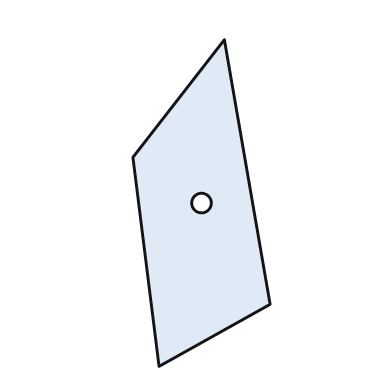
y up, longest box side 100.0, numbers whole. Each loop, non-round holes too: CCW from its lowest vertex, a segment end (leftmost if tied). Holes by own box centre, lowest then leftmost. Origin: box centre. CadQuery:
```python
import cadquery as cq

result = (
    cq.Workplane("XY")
    .moveTo(-13.0, -50.0)
    .lineTo(21.0, -31.0)
    .lineTo(7.0, 50.0)
    .lineTo(-21.0, 14.0)
    .close()
    .moveTo(0.0, 0.0)
    .circle(3.0)
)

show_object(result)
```